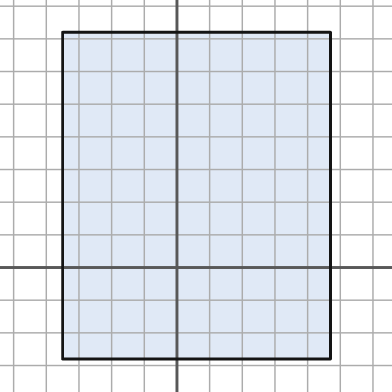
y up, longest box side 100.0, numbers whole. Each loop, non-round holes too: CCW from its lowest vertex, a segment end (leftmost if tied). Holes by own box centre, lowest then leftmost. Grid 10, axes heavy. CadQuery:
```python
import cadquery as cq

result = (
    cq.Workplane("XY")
    .moveTo(-35.0, -28.0)
    .lineTo(47.0, -28.0)
    .lineTo(47.0, 72.0)
    .lineTo(-35.0, 72.0)
    .close()
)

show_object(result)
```